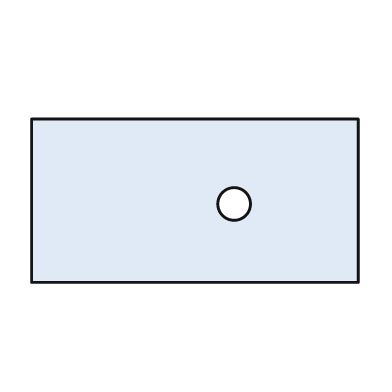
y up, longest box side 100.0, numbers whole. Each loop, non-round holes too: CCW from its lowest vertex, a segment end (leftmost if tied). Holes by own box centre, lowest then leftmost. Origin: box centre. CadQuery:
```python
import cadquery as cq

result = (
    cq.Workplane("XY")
    .moveTo(-50.0, -25.0)
    .lineTo(50.0, -25.0)
    .lineTo(50.0, 25.0)
    .lineTo(-50.0, 25.0)
    .close()
    .moveTo(12.0, -1.0)
    .circle(5.0)
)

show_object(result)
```